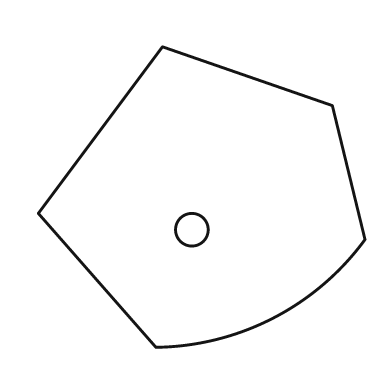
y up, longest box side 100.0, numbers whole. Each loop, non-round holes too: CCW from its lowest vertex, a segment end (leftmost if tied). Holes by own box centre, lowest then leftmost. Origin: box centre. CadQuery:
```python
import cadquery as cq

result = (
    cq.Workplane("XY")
    .moveTo(-14.0, -46.0)
    .threePointArc((22.0, -37.0), (50.0, -13.0))
    .lineTo(40.0, 28.0)
    .lineTo(-12.0, 46.0)
    .lineTo(-50.0, -5.0)
    .close()
    .moveTo(-3.0, -10.0)
    .circle(5.0)
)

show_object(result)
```